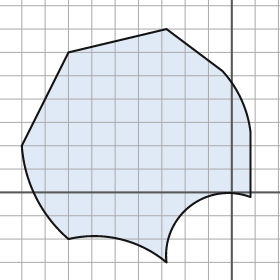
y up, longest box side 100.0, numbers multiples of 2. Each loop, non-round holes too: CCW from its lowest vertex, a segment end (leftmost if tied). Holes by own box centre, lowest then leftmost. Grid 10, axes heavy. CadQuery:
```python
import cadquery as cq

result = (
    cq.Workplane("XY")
    .moveTo(-28.0, -30.0)
    .threePointArc((-18.0, -6.0), (8.0, -2.0))
    .lineTo(8.0, 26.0)
    .threePointArc((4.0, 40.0), (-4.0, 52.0))
    .lineTo(-28.0, 70.0)
    .lineTo(-70.0, 60.0)
    .lineTo(-90.0, 20.0)
    .threePointArc((-84.0, -2.0), (-70.0, -20.0))
    .threePointArc((-48.0, -20.0), (-28.0, -30.0))
    .close()
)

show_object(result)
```